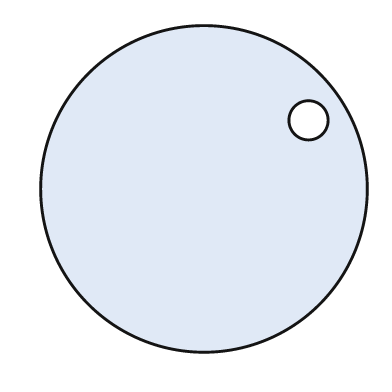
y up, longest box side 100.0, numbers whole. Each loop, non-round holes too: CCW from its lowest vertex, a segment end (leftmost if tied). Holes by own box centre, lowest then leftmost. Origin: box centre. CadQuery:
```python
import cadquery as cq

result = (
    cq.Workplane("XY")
    .moveTo(0.0, 0.0)
    .circle(50.0)
    .moveTo(32.0, 21.0)
    .circle(6.0)
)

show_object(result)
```